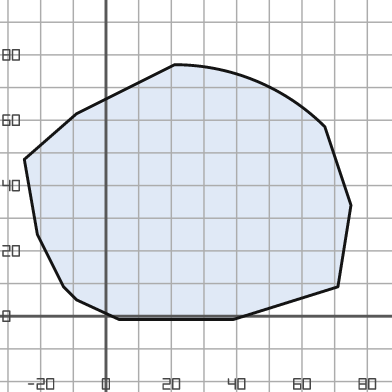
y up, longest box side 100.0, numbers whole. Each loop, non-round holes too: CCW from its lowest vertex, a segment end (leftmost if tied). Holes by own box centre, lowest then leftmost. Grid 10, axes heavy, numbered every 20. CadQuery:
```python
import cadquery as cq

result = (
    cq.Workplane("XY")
    .moveTo(4.0, -1.0)
    .lineTo(39.0, -1.0)
    .lineTo(71.0, 9.0)
    .lineTo(75.0, 34.0)
    .lineTo(67.0, 58.0)
    .threePointArc((46.0, 72.0), (21.0, 77.0))
    .lineTo(-9.0, 62.0)
    .lineTo(-25.0, 48.0)
    .lineTo(-21.0, 25.0)
    .lineTo(-13.0, 9.0)
    .lineTo(-9.0, 5.0)
    .close()
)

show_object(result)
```